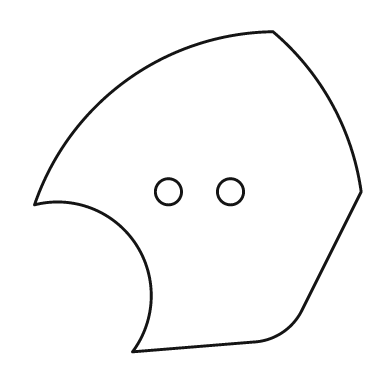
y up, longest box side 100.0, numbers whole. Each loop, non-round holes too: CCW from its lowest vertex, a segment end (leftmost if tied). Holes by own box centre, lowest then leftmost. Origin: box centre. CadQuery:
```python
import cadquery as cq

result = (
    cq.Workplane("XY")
    .moveTo(-20.0, -49.0)
    .lineTo(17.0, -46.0)
    .threePointArc((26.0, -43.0), (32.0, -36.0))
    .lineTo(50.0, 0.0)
    .threePointArc((41.0, 27.0), (23.0, 49.0))
    .threePointArc((-22.0, 34.0), (-50.0, -4.0))
    .threePointArc((-19.0, -16.0), (-20.0, -49.0))
    .close()
    .moveTo(-9.0, 0.0)
    .circle(4.0)
    .moveTo(10.0, 0.0)
    .circle(4.0)
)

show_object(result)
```